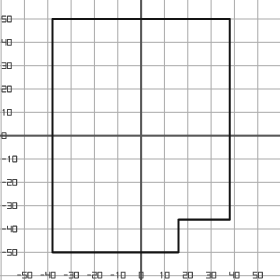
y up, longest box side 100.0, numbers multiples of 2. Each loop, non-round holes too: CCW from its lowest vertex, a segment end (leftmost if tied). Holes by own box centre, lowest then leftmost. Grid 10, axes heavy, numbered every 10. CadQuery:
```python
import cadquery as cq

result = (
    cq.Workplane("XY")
    .moveTo(-38.0, -50.0)
    .lineTo(16.0, -50.0)
    .lineTo(16.0, -36.0)
    .lineTo(38.0, -36.0)
    .lineTo(38.0, 50.0)
    .lineTo(-38.0, 50.0)
    .close()
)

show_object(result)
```